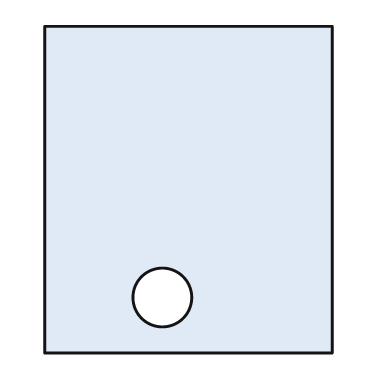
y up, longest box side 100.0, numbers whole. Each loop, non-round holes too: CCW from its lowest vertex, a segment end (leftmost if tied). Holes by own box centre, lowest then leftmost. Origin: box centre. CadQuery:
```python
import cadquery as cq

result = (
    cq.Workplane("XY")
    .moveTo(-44.0, -50.0)
    .lineTo(44.0, -50.0)
    .lineTo(44.0, 50.0)
    .lineTo(-44.0, 50.0)
    .close()
    .moveTo(-8.0, -33.0)
    .circle(9.0)
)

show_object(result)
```